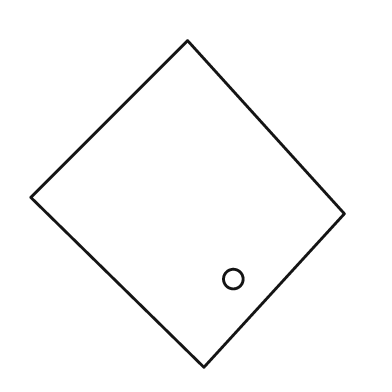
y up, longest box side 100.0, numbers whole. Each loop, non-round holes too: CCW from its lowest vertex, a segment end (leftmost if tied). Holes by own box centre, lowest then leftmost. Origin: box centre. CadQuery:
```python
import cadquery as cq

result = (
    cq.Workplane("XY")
    .moveTo(5.0, -50.0)
    .lineTo(48.0, -3.0)
    .lineTo(0.0, 50.0)
    .lineTo(-48.0, 2.0)
    .close()
    .moveTo(14.0, -23.0)
    .circle(3.0)
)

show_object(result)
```